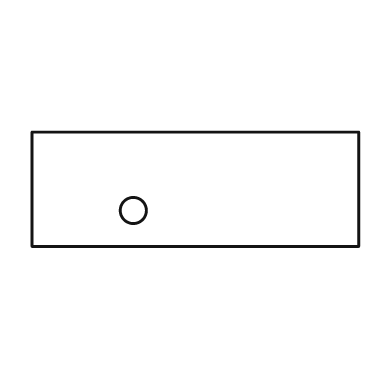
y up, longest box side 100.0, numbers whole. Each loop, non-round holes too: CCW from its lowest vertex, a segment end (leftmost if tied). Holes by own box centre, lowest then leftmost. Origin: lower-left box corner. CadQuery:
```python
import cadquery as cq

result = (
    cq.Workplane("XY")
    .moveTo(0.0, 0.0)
    .lineTo(100.0, 0.0)
    .lineTo(100.0, 35.0)
    .lineTo(0.0, 35.0)
    .close()
    .moveTo(31.0, 11.0)
    .circle(4.0)
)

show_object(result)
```